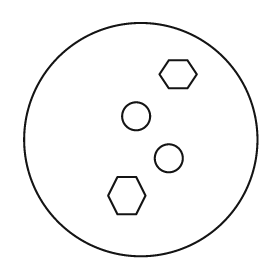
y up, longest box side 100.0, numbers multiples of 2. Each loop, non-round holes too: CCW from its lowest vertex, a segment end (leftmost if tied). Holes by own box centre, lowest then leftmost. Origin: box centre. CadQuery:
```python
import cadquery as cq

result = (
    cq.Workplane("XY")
    .moveTo(0.0, 0.0)
    .circle(50.0)
    .moveTo(-10.0, -32.0)
    .lineTo(-2.0, -32.0)
    .lineTo(2.0, -24.0)
    .lineTo(-2.0, -16.0)
    .lineTo(-10.0, -16.0)
    .lineTo(-14.0, -24.0)
    .close()
    .moveTo(12.0, -8.0)
    .circle(6.0)
    .moveTo(-2.0, 10.0)
    .circle(6.0)
    .moveTo(12.0, 22.0)
    .lineTo(20.0, 22.0)
    .lineTo(24.0, 28.0)
    .lineTo(20.0, 34.0)
    .lineTo(12.0, 34.0)
    .lineTo(8.0, 28.0)
    .close()
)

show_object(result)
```